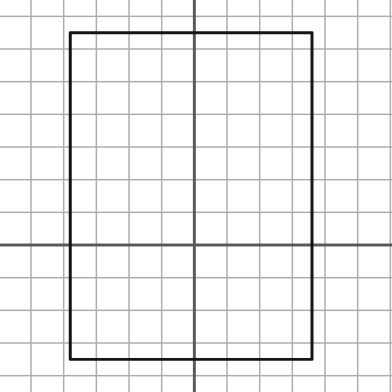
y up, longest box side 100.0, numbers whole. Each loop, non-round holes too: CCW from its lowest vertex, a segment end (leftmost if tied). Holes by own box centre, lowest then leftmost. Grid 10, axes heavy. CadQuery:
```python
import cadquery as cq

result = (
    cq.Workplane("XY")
    .moveTo(-38.0, -35.0)
    .lineTo(36.0, -35.0)
    .lineTo(36.0, 65.0)
    .lineTo(-38.0, 65.0)
    .close()
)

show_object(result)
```